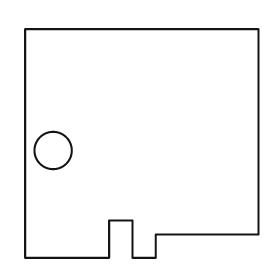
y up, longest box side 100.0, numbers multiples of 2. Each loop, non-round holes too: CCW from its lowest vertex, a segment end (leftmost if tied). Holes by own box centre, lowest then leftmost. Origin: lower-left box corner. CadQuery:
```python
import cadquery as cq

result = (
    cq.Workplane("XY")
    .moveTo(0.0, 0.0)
    .lineTo(36.0, 0.0)
    .lineTo(36.0, 16.0)
    .lineTo(46.0, 16.0)
    .lineTo(46.0, 0.0)
    .lineTo(56.0, 0.0)
    .lineTo(56.0, 10.0)
    .lineTo(100.0, 10.0)
    .lineTo(100.0, 98.0)
    .lineTo(0.0, 98.0)
    .close()
    .moveTo(12.0, 46.0)
    .circle(8.0)
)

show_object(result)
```